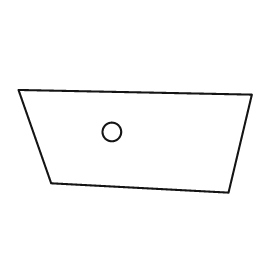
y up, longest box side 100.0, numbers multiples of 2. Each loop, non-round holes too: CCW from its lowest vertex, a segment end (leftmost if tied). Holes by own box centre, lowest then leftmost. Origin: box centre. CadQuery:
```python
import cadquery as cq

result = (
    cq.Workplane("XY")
    .moveTo(40.0, -22.0)
    .lineTo(50.0, 20.0)
    .lineTo(-50.0, 22.0)
    .lineTo(-36.0, -18.0)
    .close()
    .moveTo(-10.0, 4.0)
    .circle(4.0)
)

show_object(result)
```